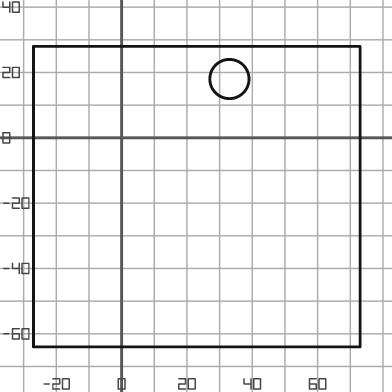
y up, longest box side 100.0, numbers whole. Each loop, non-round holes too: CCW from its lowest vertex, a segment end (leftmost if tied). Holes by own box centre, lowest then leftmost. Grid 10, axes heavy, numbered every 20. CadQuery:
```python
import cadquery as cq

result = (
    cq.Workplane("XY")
    .moveTo(-27.0, -64.0)
    .lineTo(73.0, -64.0)
    .lineTo(73.0, 28.0)
    .lineTo(-27.0, 28.0)
    .close()
    .moveTo(33.0, 18.0)
    .circle(6.0)
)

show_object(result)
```